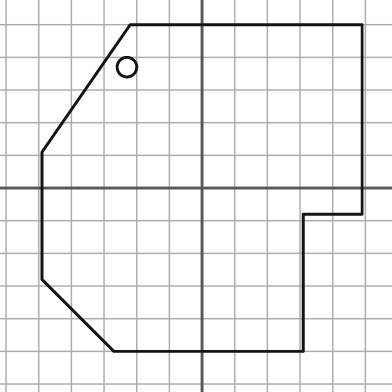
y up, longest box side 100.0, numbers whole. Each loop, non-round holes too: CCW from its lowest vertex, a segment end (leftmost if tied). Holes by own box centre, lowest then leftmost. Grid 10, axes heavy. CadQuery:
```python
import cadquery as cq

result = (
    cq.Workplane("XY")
    .moveTo(-27.0, -50.0)
    .lineTo(31.0, -50.0)
    .lineTo(31.0, -8.0)
    .lineTo(49.0, -8.0)
    .lineTo(49.0, 50.0)
    .lineTo(-22.0, 50.0)
    .lineTo(-49.0, 11.0)
    .lineTo(-49.0, -28.0)
    .close()
    .moveTo(-23.0, 37.0)
    .circle(3.0)
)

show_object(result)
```